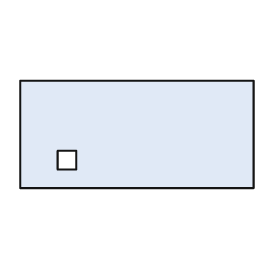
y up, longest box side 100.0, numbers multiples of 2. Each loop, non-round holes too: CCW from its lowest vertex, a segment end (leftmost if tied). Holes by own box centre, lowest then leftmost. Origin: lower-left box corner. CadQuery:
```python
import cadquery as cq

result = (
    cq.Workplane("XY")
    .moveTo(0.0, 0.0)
    .lineTo(100.0, 0.0)
    .lineTo(100.0, 46.0)
    .lineTo(0.0, 46.0)
    .close()
    .moveTo(16.0, 8.0)
    .lineTo(24.0, 8.0)
    .lineTo(24.0, 16.0)
    .lineTo(16.0, 16.0)
    .close()
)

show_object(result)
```